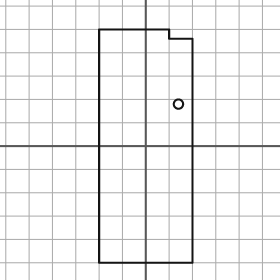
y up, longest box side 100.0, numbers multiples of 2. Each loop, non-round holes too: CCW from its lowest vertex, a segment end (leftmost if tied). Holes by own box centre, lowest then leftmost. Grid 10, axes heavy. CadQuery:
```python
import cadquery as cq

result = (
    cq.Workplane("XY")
    .moveTo(-20.0, -50.0)
    .lineTo(20.0, -50.0)
    .lineTo(20.0, 46.0)
    .lineTo(10.0, 46.0)
    .lineTo(10.0, 50.0)
    .lineTo(-20.0, 50.0)
    .close()
    .moveTo(14.0, 18.0)
    .circle(2.0)
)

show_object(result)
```